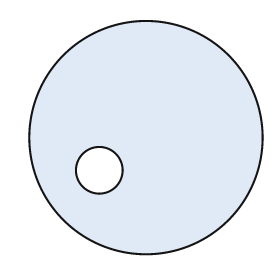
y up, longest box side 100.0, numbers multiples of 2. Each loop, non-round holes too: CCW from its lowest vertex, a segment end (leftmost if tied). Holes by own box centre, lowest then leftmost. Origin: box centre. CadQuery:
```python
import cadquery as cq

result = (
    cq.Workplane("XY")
    .moveTo(0.0, 0.0)
    .circle(50.0)
    .moveTo(-20.0, -14.0)
    .circle(10.0)
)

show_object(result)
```